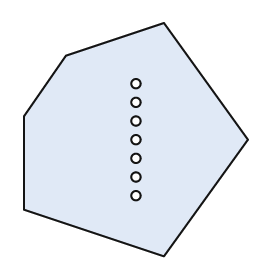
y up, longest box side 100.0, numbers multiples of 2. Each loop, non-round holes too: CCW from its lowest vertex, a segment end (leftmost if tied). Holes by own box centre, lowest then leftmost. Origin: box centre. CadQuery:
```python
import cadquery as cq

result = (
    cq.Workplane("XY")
    .moveTo(12.0, -50.0)
    .lineTo(48.0, 0.0)
    .lineTo(12.0, 50.0)
    .lineTo(-30.0, 36.0)
    .lineTo(-48.0, 10.0)
    .lineTo(-48.0, -30.0)
    .close()
    .moveTo(0.0, -24.0)
    .circle(2.0)
    .moveTo(0.0, -16.0)
    .circle(2.0)
    .moveTo(0.0, -8.0)
    .circle(2.0)
    .moveTo(0.0, 0.0)
    .circle(2.0)
    .moveTo(0.0, 8.0)
    .circle(2.0)
    .moveTo(0.0, 16.0)
    .circle(2.0)
    .moveTo(0.0, 24.0)
    .circle(2.0)
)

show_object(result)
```